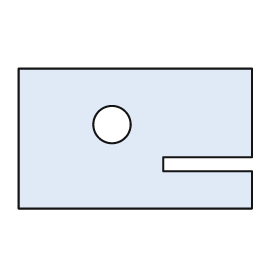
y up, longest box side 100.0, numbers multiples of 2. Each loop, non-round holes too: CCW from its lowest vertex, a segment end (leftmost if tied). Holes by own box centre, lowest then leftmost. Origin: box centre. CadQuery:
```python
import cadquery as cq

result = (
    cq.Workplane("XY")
    .moveTo(-50.0, -30.0)
    .lineTo(50.0, -30.0)
    .lineTo(50.0, -14.0)
    .lineTo(12.0, -14.0)
    .lineTo(12.0, -8.0)
    .lineTo(50.0, -8.0)
    .lineTo(50.0, 30.0)
    .lineTo(-50.0, 30.0)
    .close()
    .moveTo(-10.0, 6.0)
    .circle(8.0)
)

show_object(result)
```